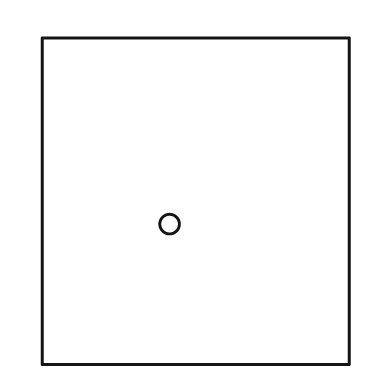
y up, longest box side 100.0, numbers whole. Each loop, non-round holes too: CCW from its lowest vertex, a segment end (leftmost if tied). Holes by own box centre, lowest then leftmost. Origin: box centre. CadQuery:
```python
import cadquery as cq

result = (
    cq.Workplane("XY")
    .moveTo(-47.0, -50.0)
    .lineTo(47.0, -50.0)
    .lineTo(47.0, 50.0)
    .lineTo(-47.0, 50.0)
    .close()
    .moveTo(-8.0, -7.0)
    .circle(3.0)
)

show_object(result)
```